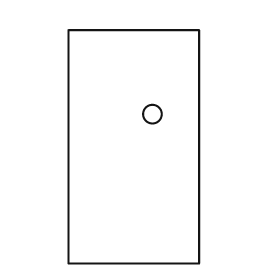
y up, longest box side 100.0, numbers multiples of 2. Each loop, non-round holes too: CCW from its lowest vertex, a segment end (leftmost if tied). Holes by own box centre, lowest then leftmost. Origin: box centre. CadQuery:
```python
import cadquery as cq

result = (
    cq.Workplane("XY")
    .moveTo(-28.0, -50.0)
    .lineTo(28.0, -50.0)
    .lineTo(28.0, 50.0)
    .lineTo(-28.0, 50.0)
    .close()
    .moveTo(8.0, 14.0)
    .circle(4.0)
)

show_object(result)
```